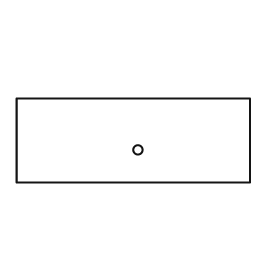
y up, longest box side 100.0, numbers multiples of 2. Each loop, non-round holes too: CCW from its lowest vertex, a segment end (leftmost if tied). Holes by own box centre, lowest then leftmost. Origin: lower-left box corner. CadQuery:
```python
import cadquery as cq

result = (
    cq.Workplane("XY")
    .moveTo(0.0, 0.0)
    .lineTo(100.0, 0.0)
    .lineTo(100.0, 36.0)
    .lineTo(0.0, 36.0)
    .close()
    .moveTo(52.0, 14.0)
    .circle(2.0)
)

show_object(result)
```